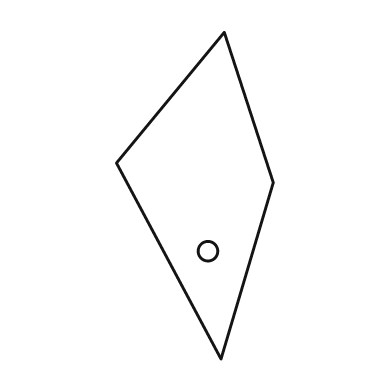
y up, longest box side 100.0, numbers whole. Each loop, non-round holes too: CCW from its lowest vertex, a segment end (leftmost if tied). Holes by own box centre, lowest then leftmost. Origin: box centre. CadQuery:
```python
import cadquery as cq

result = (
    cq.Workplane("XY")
    .moveTo(8.0, -50.0)
    .lineTo(24.0, 4.0)
    .lineTo(9.0, 50.0)
    .lineTo(-24.0, 10.0)
    .close()
    .moveTo(4.0, -17.0)
    .circle(3.0)
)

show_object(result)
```